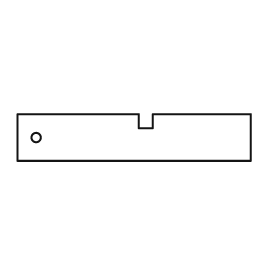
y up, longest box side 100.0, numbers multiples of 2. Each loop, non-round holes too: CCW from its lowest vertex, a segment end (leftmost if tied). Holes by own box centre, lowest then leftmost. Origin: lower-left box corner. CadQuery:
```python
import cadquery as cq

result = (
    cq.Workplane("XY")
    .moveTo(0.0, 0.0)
    .lineTo(100.0, 0.0)
    .lineTo(100.0, 20.0)
    .lineTo(58.0, 20.0)
    .lineTo(58.0, 14.0)
    .lineTo(52.0, 14.0)
    .lineTo(52.0, 20.0)
    .lineTo(0.0, 20.0)
    .close()
    .moveTo(8.0, 10.0)
    .circle(2.0)
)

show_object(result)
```